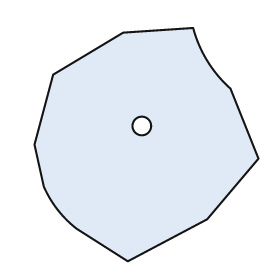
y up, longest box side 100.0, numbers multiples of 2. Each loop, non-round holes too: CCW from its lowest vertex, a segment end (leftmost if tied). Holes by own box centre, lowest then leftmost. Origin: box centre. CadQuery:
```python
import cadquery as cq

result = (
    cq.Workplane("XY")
    .moveTo(-8.0, -50.0)
    .lineTo(26.0, -32.0)
    .lineTo(48.0, -6.0)
    .lineTo(36.0, 24.0)
    .threePointArc((26.0, 36.0), (20.0, 50.0))
    .lineTo(-10.0, 48.0)
    .lineTo(-40.0, 30.0)
    .lineTo(-48.0, 0.0)
    .lineTo(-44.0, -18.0)
    .threePointArc((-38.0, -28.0), (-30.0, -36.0))
    .close()
    .moveTo(-2.0, 8.0)
    .circle(4.0)
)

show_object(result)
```